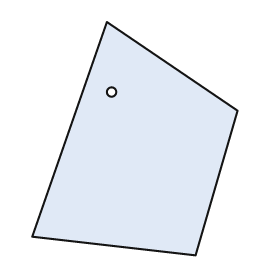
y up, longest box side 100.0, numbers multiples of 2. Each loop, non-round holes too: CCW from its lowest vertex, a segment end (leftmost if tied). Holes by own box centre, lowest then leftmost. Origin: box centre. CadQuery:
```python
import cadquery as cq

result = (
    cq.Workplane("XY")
    .moveTo(26.0, -50.0)
    .lineTo(44.0, 12.0)
    .lineTo(-12.0, 50.0)
    .lineTo(-44.0, -42.0)
    .close()
    .moveTo(-10.0, 20.0)
    .circle(2.0)
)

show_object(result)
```